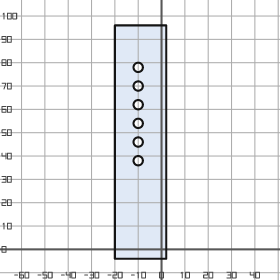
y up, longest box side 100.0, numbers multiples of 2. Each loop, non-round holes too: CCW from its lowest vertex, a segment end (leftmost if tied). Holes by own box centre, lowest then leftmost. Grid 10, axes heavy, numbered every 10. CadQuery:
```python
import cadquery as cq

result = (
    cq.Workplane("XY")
    .moveTo(-20.0, -4.0)
    .lineTo(2.0, -4.0)
    .lineTo(2.0, 96.0)
    .lineTo(-20.0, 96.0)
    .close()
    .moveTo(-10.0, 38.0)
    .circle(2.0)
    .moveTo(-10.0, 46.0)
    .circle(2.0)
    .moveTo(-10.0, 54.0)
    .circle(2.0)
    .moveTo(-10.0, 62.0)
    .circle(2.0)
    .moveTo(-10.0, 70.0)
    .circle(2.0)
    .moveTo(-10.0, 78.0)
    .circle(2.0)
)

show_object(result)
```